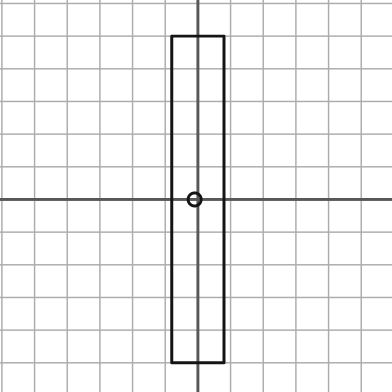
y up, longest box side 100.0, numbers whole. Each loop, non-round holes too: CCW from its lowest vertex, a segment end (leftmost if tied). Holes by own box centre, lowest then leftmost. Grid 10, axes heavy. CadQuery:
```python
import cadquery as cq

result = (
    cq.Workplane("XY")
    .moveTo(-8.0, -50.0)
    .lineTo(8.0, -50.0)
    .lineTo(8.0, 50.0)
    .lineTo(-8.0, 50.0)
    .close()
    .moveTo(-1.0, 0.0)
    .circle(2.0)
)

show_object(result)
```